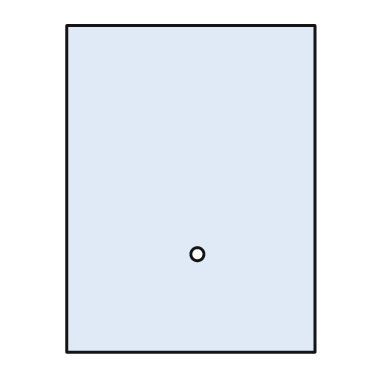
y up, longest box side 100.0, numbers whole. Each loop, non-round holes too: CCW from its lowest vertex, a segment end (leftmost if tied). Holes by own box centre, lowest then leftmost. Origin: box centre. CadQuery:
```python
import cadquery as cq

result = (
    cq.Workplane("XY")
    .moveTo(-38.0, -50.0)
    .lineTo(38.0, -50.0)
    .lineTo(38.0, 50.0)
    .lineTo(-38.0, 50.0)
    .close()
    .moveTo(2.0, -20.0)
    .circle(2.0)
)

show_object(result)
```